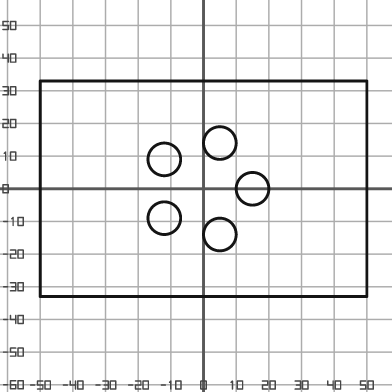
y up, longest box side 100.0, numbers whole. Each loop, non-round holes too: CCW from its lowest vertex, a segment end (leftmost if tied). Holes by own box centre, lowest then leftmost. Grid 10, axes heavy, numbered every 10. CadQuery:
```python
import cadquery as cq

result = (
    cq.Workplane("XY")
    .moveTo(-50.0, -33.0)
    .lineTo(50.0, -33.0)
    .lineTo(50.0, 33.0)
    .lineTo(-50.0, 33.0)
    .close()
    .moveTo(5.0, -14.0)
    .circle(5.0)
    .moveTo(-12.0, -9.0)
    .circle(5.0)
    .moveTo(15.0, 0.0)
    .circle(5.0)
    .moveTo(-12.0, 9.0)
    .circle(5.0)
    .moveTo(5.0, 14.0)
    .circle(5.0)
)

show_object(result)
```